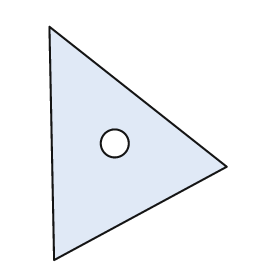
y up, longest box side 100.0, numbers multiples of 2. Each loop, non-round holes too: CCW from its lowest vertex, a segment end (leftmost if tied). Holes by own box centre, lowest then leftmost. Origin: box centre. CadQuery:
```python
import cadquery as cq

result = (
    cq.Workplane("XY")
    .moveTo(-36.0, -50.0)
    .lineTo(38.0, -10.0)
    .lineTo(-38.0, 50.0)
    .close()
    .moveTo(-10.0, 0.0)
    .circle(6.0)
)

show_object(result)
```